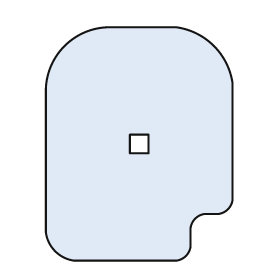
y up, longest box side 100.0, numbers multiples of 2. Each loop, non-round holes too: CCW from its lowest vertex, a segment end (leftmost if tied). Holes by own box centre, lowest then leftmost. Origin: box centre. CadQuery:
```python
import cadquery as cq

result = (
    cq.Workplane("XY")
    .moveTo(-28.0, -50.0)
    .lineTo(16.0, -50.0)
    .threePointArc((20.0, -48.0), (22.0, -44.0))
    .lineTo(22.0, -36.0)
    .threePointArc((24.0, -32.0), (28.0, -30.0))
    .lineTo(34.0, -30.0)
    .threePointArc((38.0, -28.0), (40.0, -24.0))
    .lineTo(40.0, 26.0)
    .threePointArc((32.0, 42.0), (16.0, 50.0))
    .lineTo(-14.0, 50.0)
    .threePointArc((-32.0, 42.0), (-40.0, 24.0))
    .lineTo(-40.0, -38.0)
    .threePointArc((-36.0, -46.0), (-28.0, -50.0))
    .close()
    .moveTo(-4.0, -4.0)
    .lineTo(4.0, -4.0)
    .lineTo(4.0, 4.0)
    .lineTo(-4.0, 4.0)
    .close()
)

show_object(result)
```